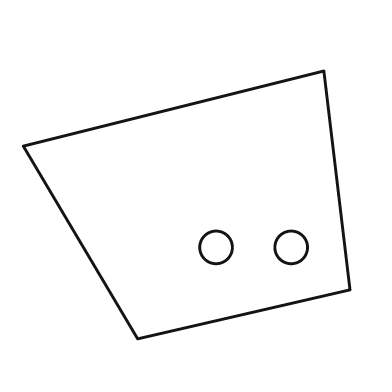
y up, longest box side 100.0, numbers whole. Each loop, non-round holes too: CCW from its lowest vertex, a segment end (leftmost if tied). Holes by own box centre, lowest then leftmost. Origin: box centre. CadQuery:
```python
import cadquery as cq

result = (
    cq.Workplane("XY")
    .moveTo(-15.0, -41.0)
    .lineTo(50.0, -26.0)
    .lineTo(42.0, 41.0)
    .lineTo(-50.0, 18.0)
    .close()
    .moveTo(9.0, -13.0)
    .circle(5.0)
    .moveTo(32.0, -13.0)
    .circle(5.0)
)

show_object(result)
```